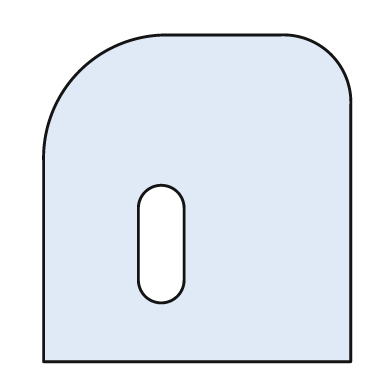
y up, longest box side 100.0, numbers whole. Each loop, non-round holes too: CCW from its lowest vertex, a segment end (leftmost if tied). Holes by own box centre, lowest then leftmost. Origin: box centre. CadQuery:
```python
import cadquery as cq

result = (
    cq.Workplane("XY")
    .moveTo(-47.0, -50.0)
    .lineTo(47.0, -50.0)
    .lineTo(47.0, 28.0)
    .threePointArc((41.0, 44.0), (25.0, 50.0))
    .lineTo(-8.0, 50.0)
    .threePointArc((-36.0, 39.0), (-47.0, 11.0))
    .close()
    .moveTo(-18.0, -25.0)
    .threePointArc((-11.0, -32.0), (-4.0, -25.0))
    .lineTo(-4.0, -3.0)
    .threePointArc((-11.0, 4.0), (-18.0, -3.0))
    .close()
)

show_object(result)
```